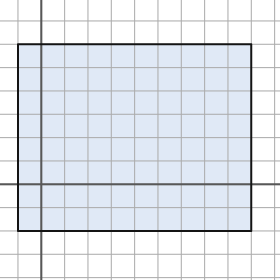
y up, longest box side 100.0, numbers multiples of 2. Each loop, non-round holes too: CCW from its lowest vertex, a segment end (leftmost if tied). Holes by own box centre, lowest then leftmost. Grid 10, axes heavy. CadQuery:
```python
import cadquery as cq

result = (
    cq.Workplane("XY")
    .moveTo(-10.0, -20.0)
    .lineTo(90.0, -20.0)
    .lineTo(90.0, 60.0)
    .lineTo(-10.0, 60.0)
    .close()
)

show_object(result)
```